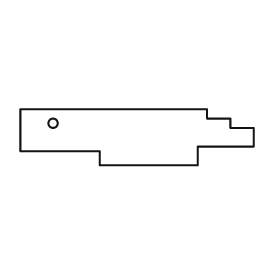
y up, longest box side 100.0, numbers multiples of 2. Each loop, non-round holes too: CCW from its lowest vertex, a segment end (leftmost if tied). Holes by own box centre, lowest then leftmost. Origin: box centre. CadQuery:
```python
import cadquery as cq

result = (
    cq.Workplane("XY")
    .moveTo(-16.0, -12.0)
    .lineTo(26.0, -12.0)
    .lineTo(26.0, -4.0)
    .lineTo(50.0, -4.0)
    .lineTo(50.0, 4.0)
    .lineTo(40.0, 4.0)
    .lineTo(40.0, 8.0)
    .lineTo(30.0, 8.0)
    .lineTo(30.0, 12.0)
    .lineTo(-50.0, 12.0)
    .lineTo(-50.0, -6.0)
    .lineTo(-16.0, -6.0)
    .close()
    .moveTo(-36.0, 6.0)
    .circle(2.0)
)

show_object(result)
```